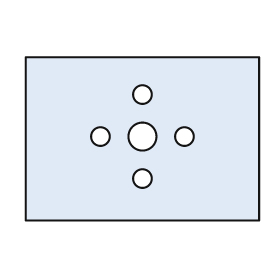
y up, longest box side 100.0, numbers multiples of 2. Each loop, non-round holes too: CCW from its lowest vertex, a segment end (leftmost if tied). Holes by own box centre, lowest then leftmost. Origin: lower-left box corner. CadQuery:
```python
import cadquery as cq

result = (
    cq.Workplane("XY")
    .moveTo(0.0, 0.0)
    .lineTo(100.0, 0.0)
    .lineTo(100.0, 70.0)
    .lineTo(0.0, 70.0)
    .close()
    .moveTo(50.0, 18.0)
    .circle(4.0)
    .moveTo(32.0, 36.0)
    .circle(4.0)
    .moveTo(50.0, 36.0)
    .circle(6.0)
    .moveTo(68.0, 36.0)
    .circle(4.0)
    .moveTo(50.0, 54.0)
    .circle(4.0)
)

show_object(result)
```